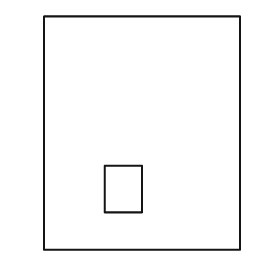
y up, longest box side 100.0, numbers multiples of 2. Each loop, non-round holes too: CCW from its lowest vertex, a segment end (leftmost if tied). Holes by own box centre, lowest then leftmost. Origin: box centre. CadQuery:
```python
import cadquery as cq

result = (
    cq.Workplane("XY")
    .moveTo(-42.0, -50.0)
    .lineTo(42.0, -50.0)
    .lineTo(42.0, 50.0)
    .lineTo(-42.0, 50.0)
    .close()
    .moveTo(-16.0, -34.0)
    .lineTo(0.0, -34.0)
    .lineTo(0.0, -14.0)
    .lineTo(-16.0, -14.0)
    .close()
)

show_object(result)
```